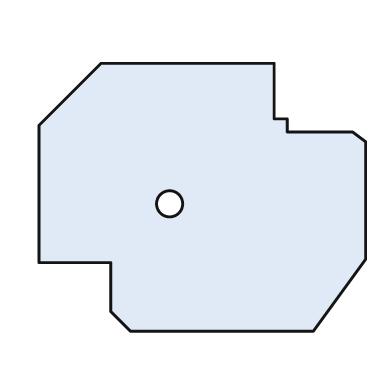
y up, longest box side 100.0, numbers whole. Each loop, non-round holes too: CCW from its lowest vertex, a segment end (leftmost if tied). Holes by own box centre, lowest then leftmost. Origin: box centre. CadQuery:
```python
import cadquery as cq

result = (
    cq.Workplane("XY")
    .moveTo(-22.0, -41.0)
    .lineTo(34.0, -41.0)
    .lineTo(50.0, -19.0)
    .lineTo(50.0, 17.0)
    .lineTo(46.0, 20.0)
    .lineTo(26.0, 20.0)
    .lineTo(26.0, 24.0)
    .lineTo(22.0, 24.0)
    .lineTo(22.0, 41.0)
    .lineTo(-31.0, 41.0)
    .lineTo(-50.0, 22.0)
    .lineTo(-50.0, -20.0)
    .lineTo(-28.0, -20.0)
    .lineTo(-28.0, -35.0)
    .close()
    .moveTo(-10.0, -2.0)
    .circle(4.0)
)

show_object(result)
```